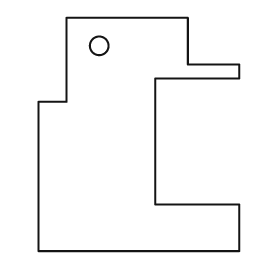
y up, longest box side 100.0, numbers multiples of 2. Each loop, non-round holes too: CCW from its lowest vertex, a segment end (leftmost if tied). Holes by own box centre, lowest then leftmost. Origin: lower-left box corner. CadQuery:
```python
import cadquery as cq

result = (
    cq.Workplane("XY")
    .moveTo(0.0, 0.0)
    .lineTo(86.0, 0.0)
    .lineTo(86.0, 20.0)
    .lineTo(50.0, 20.0)
    .lineTo(50.0, 74.0)
    .lineTo(86.0, 74.0)
    .lineTo(86.0, 80.0)
    .lineTo(64.0, 80.0)
    .lineTo(64.0, 100.0)
    .lineTo(12.0, 100.0)
    .lineTo(12.0, 64.0)
    .lineTo(0.0, 64.0)
    .close()
    .moveTo(26.0, 88.0)
    .circle(4.0)
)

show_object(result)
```